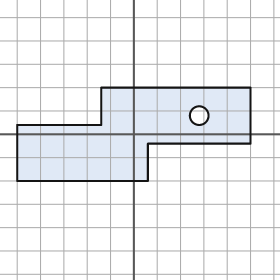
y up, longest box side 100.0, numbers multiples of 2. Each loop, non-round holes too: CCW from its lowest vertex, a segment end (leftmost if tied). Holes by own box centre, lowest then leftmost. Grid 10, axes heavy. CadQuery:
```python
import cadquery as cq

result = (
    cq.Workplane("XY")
    .moveTo(-50.0, -20.0)
    .lineTo(6.0, -20.0)
    .lineTo(6.0, -4.0)
    .lineTo(50.0, -4.0)
    .lineTo(50.0, 20.0)
    .lineTo(-14.0, 20.0)
    .lineTo(-14.0, 4.0)
    .lineTo(-50.0, 4.0)
    .close()
    .moveTo(28.0, 8.0)
    .circle(4.0)
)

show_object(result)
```